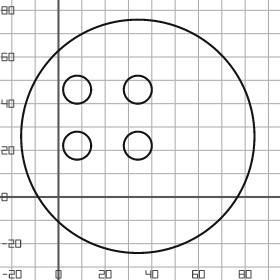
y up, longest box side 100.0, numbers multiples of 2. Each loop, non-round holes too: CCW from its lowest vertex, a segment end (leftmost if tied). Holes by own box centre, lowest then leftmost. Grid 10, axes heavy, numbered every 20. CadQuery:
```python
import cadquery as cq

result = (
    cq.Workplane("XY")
    .moveTo(34.0, 26.0)
    .circle(50.0)
    .moveTo(8.0, 22.0)
    .circle(6.0)
    .moveTo(34.0, 22.0)
    .circle(6.0)
    .moveTo(8.0, 46.0)
    .circle(6.0)
    .moveTo(34.0, 46.0)
    .circle(6.0)
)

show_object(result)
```